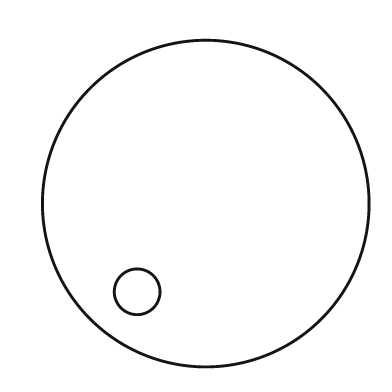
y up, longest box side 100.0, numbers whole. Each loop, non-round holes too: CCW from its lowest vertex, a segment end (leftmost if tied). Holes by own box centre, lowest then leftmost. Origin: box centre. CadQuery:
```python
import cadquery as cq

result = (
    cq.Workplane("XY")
    .moveTo(0.0, 0.0)
    .circle(50.0)
    .moveTo(-21.0, -27.0)
    .circle(7.0)
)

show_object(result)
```